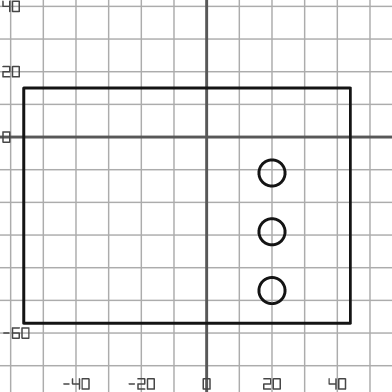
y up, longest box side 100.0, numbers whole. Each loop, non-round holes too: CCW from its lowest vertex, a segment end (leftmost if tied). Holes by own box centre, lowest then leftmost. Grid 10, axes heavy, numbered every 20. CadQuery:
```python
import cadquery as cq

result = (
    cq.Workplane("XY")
    .moveTo(-56.0, -57.0)
    .lineTo(44.0, -57.0)
    .lineTo(44.0, 15.0)
    .lineTo(-56.0, 15.0)
    .close()
    .moveTo(20.0, -47.0)
    .circle(4.0)
    .moveTo(20.0, -29.0)
    .circle(4.0)
    .moveTo(20.0, -11.0)
    .circle(4.0)
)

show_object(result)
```